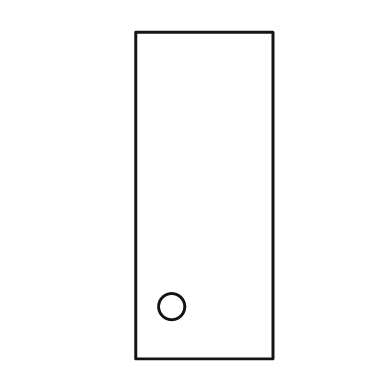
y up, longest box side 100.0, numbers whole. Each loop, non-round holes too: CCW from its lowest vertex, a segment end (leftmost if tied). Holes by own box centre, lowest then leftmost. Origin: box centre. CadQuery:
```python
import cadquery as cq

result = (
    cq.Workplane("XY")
    .moveTo(-21.0, -50.0)
    .lineTo(21.0, -50.0)
    .lineTo(21.0, 50.0)
    .lineTo(-21.0, 50.0)
    .close()
    .moveTo(-10.0, -34.0)
    .circle(4.0)
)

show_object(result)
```